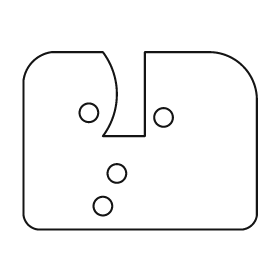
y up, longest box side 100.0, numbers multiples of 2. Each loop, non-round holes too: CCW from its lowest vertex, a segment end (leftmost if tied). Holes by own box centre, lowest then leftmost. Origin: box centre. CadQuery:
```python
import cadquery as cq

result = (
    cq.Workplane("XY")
    .moveTo(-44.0, -38.0)
    .lineTo(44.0, -38.0)
    .threePointArc((48.0, -36.0), (50.0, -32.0))
    .lineTo(50.0, 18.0)
    .threePointArc((44.0, 32.0), (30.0, 38.0))
    .lineTo(2.0, 38.0)
    .lineTo(2.0, 2.0)
    .lineTo(-16.0, 2.0)
    .threePointArc((-10.0, 20.0), (-16.0, 38.0))
    .lineTo(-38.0, 38.0)
    .threePointArc((-46.0, 34.0), (-50.0, 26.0))
    .lineTo(-50.0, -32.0)
    .threePointArc((-48.0, -36.0), (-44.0, -38.0))
    .close()
    .moveTo(-16.0, -28.0)
    .circle(4.0)
    .moveTo(-10.0, -14.0)
    .circle(4.0)
    .moveTo(10.0, 10.0)
    .circle(4.0)
    .moveTo(-22.0, 12.0)
    .circle(4.0)
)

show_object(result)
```